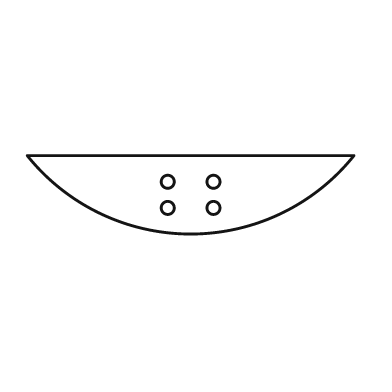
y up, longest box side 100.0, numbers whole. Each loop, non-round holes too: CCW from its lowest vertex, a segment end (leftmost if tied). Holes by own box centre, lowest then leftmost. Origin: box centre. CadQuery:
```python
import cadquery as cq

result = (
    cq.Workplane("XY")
    .moveTo(-50.0, 12.0)
    .threePointArc((0.0, -12.0), (50.0, 12.0))
    .close()
    .moveTo(-7.0, -4.0)
    .circle(2.0)
    .moveTo(7.0, -4.0)
    .circle(2.0)
    .moveTo(-7.0, 4.0)
    .circle(2.0)
    .moveTo(7.0, 4.0)
    .circle(2.0)
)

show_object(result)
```